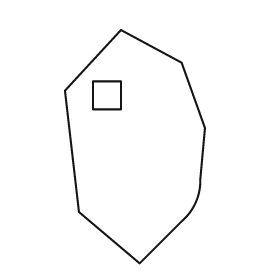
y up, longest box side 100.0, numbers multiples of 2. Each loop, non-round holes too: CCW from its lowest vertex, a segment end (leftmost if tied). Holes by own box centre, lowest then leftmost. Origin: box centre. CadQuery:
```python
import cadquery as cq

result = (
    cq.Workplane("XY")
    .moveTo(2.0, -50.0)
    .lineTo(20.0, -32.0)
    .threePointArc((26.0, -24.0), (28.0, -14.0))
    .lineTo(30.0, 8.0)
    .lineTo(20.0, 36.0)
    .lineTo(-6.0, 50.0)
    .lineTo(-30.0, 24.0)
    .lineTo(-24.0, -28.0)
    .close()
    .moveTo(-18.0, 16.0)
    .lineTo(-6.0, 16.0)
    .lineTo(-6.0, 28.0)
    .lineTo(-18.0, 28.0)
    .close()
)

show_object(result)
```